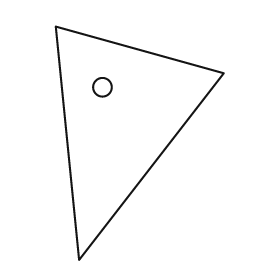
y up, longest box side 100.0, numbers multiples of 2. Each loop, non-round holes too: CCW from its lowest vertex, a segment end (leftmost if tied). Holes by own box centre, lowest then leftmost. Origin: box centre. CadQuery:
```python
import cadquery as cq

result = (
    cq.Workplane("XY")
    .moveTo(-26.0, -50.0)
    .lineTo(36.0, 30.0)
    .lineTo(-36.0, 50.0)
    .close()
    .moveTo(-16.0, 24.0)
    .circle(4.0)
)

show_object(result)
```